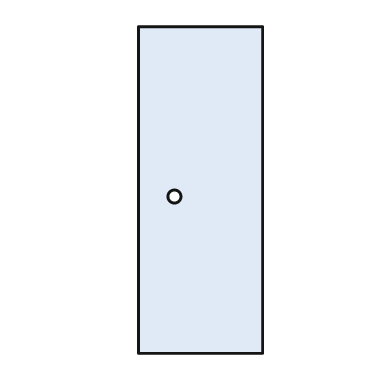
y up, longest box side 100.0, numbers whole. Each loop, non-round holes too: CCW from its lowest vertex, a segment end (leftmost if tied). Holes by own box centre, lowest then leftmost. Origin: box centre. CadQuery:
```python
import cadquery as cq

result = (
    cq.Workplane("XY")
    .moveTo(-19.0, -50.0)
    .lineTo(19.0, -50.0)
    .lineTo(19.0, 50.0)
    .lineTo(-19.0, 50.0)
    .close()
    .moveTo(-8.0, -2.0)
    .circle(2.0)
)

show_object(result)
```